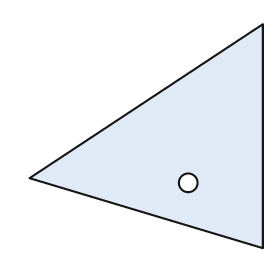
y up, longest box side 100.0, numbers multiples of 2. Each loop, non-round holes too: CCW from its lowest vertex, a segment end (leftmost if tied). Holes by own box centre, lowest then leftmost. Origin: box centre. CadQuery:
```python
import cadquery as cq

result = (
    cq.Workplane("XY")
    .moveTo(50.0, -48.0)
    .lineTo(50.0, 48.0)
    .lineTo(-50.0, -18.0)
    .close()
    .moveTo(18.0, -20.0)
    .circle(4.0)
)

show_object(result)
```